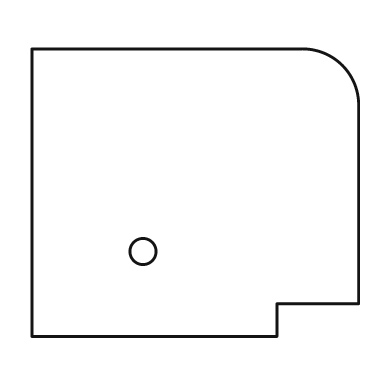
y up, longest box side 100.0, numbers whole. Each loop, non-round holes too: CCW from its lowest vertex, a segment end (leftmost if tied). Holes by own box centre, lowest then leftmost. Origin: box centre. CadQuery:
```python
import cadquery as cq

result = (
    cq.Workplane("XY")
    .moveTo(-50.0, -44.0)
    .lineTo(25.0, -44.0)
    .lineTo(25.0, -34.0)
    .lineTo(50.0, -34.0)
    .lineTo(50.0, 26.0)
    .threePointArc((45.0, 39.0), (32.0, 44.0))
    .lineTo(-50.0, 44.0)
    .close()
    .moveTo(-16.0, -18.0)
    .circle(4.0)
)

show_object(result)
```